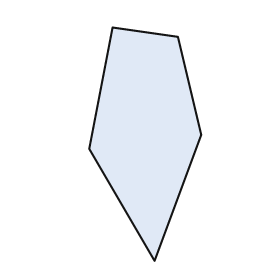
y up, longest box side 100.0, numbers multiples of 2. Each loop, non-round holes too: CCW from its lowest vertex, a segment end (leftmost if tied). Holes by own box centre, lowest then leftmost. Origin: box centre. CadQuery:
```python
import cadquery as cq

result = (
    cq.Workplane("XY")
    .moveTo(4.0, -50.0)
    .lineTo(24.0, 4.0)
    .lineTo(14.0, 46.0)
    .lineTo(-14.0, 50.0)
    .lineTo(-24.0, -2.0)
    .close()
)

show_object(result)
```